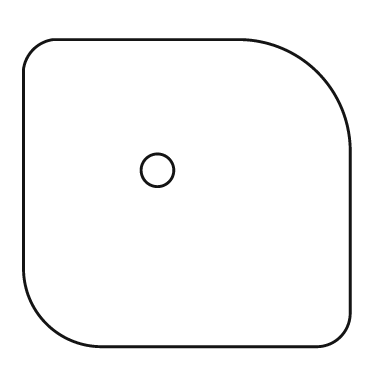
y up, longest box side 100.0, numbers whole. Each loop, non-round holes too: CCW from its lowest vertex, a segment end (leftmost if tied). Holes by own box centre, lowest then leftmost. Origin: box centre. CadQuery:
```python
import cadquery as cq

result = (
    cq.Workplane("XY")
    .moveTo(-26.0, -47.0)
    .lineTo(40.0, -47.0)
    .threePointArc((47.0, -44.0), (50.0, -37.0))
    .lineTo(50.0, 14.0)
    .threePointArc((40.0, 37.0), (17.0, 47.0))
    .lineTo(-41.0, 47.0)
    .threePointArc((-47.0, 44.0), (-50.0, 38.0))
    .lineTo(-50.0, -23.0)
    .threePointArc((-43.0, -40.0), (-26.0, -47.0))
    .close()
    .moveTo(-9.0, 7.0)
    .circle(5.0)
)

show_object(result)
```